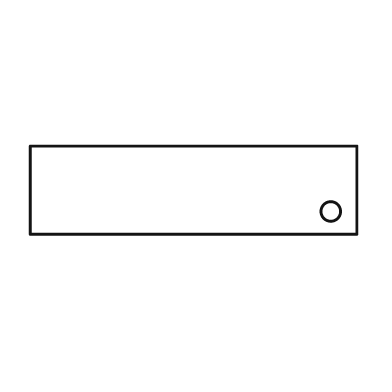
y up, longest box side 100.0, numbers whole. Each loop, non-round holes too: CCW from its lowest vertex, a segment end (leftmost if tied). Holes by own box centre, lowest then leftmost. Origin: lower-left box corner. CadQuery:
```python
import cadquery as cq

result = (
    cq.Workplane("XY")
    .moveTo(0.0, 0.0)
    .lineTo(100.0, 0.0)
    .lineTo(100.0, 27.0)
    .lineTo(0.0, 27.0)
    .close()
    .moveTo(92.0, 7.0)
    .circle(3.0)
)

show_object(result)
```